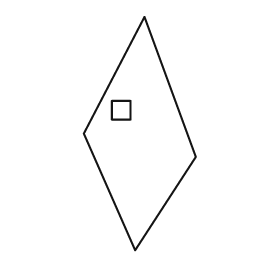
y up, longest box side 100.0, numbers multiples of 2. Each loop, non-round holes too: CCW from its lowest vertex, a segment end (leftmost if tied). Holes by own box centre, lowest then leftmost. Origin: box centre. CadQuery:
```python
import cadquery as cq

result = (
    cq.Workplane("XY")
    .moveTo(-2.0, -50.0)
    .lineTo(24.0, -10.0)
    .lineTo(2.0, 50.0)
    .lineTo(-24.0, 0.0)
    .close()
    .moveTo(-12.0, 6.0)
    .lineTo(-4.0, 6.0)
    .lineTo(-4.0, 14.0)
    .lineTo(-12.0, 14.0)
    .close()
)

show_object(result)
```